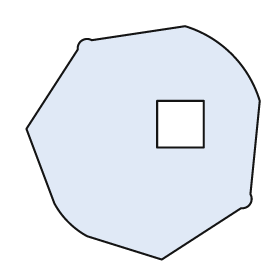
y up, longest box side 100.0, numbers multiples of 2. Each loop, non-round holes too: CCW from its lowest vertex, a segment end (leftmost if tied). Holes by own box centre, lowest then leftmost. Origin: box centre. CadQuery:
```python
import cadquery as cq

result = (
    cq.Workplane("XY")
    .moveTo(8.0, -50.0)
    .lineTo(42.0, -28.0)
    .threePointArc((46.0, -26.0), (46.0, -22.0))
    .lineTo(50.0, 18.0)
    .threePointArc((38.0, 38.0), (18.0, 50.0))
    .lineTo(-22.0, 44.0)
    .threePointArc((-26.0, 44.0), (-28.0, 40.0))
    .lineTo(-50.0, 6.0)
    .lineTo(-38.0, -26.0)
    .threePointArc((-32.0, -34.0), (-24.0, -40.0))
    .close()
    .moveTo(6.0, -2.0)
    .lineTo(26.0, -2.0)
    .lineTo(26.0, 18.0)
    .lineTo(6.0, 18.0)
    .close()
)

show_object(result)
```